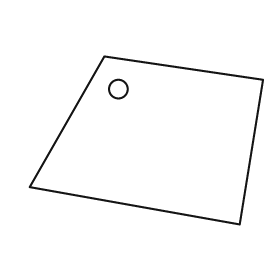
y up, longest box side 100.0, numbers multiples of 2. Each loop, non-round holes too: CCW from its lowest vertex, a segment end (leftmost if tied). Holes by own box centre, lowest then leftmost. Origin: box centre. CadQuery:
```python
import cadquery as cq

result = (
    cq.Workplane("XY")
    .moveTo(40.0, -36.0)
    .lineTo(50.0, 26.0)
    .lineTo(-18.0, 36.0)
    .lineTo(-50.0, -20.0)
    .close()
    .moveTo(-12.0, 22.0)
    .circle(4.0)
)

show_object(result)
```